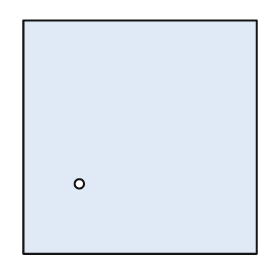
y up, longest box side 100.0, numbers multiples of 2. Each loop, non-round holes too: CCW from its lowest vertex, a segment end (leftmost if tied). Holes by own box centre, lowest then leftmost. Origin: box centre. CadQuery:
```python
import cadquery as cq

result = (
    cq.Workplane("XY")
    .moveTo(-50.0, -50.0)
    .lineTo(50.0, -50.0)
    .lineTo(50.0, 50.0)
    .lineTo(-50.0, 50.0)
    .close()
    .moveTo(-26.0, -20.0)
    .circle(2.0)
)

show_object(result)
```